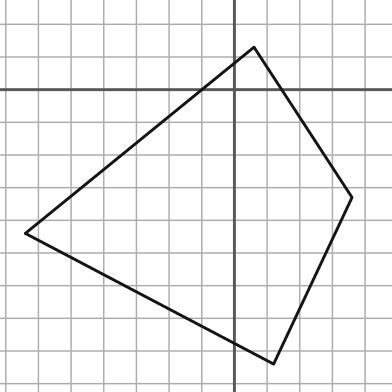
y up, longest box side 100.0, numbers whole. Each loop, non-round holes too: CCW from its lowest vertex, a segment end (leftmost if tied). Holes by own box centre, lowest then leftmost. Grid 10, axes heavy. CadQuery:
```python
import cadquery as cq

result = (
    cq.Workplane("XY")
    .moveTo(12.0, -84.0)
    .lineTo(36.0, -33.0)
    .lineTo(6.0, 13.0)
    .lineTo(-64.0, -44.0)
    .close()
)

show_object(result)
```